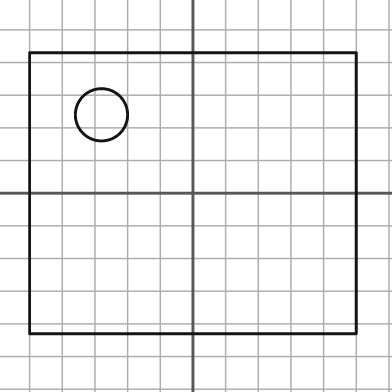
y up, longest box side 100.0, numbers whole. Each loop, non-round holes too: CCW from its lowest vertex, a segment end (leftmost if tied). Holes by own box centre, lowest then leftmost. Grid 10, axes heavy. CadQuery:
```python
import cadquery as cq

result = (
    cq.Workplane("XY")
    .moveTo(-50.0, -43.0)
    .lineTo(50.0, -43.0)
    .lineTo(50.0, 43.0)
    .lineTo(-50.0, 43.0)
    .close()
    .moveTo(-28.0, 24.0)
    .circle(8.0)
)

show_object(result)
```